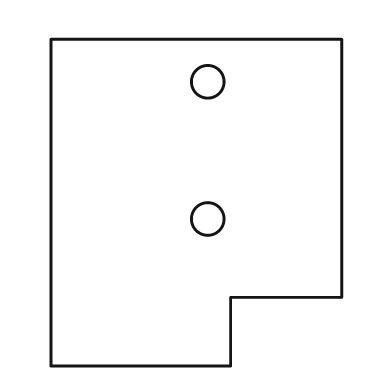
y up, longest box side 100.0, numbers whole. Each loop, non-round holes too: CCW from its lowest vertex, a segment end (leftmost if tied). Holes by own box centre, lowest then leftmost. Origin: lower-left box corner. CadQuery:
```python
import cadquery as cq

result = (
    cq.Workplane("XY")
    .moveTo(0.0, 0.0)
    .lineTo(55.0, 0.0)
    .lineTo(55.0, 21.0)
    .lineTo(89.0, 21.0)
    .lineTo(89.0, 100.0)
    .lineTo(0.0, 100.0)
    .close()
    .moveTo(48.0, 45.0)
    .circle(5.0)
    .moveTo(48.0, 87.0)
    .circle(5.0)
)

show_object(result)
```